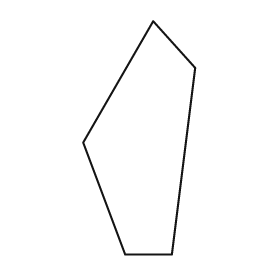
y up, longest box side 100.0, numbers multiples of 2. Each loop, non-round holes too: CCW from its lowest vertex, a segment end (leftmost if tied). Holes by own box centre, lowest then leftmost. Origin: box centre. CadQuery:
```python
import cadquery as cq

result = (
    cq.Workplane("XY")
    .moveTo(-6.0, -50.0)
    .lineTo(14.0, -50.0)
    .lineTo(24.0, 30.0)
    .lineTo(6.0, 50.0)
    .lineTo(-24.0, -2.0)
    .close()
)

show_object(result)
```